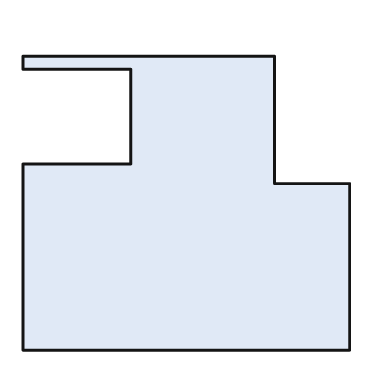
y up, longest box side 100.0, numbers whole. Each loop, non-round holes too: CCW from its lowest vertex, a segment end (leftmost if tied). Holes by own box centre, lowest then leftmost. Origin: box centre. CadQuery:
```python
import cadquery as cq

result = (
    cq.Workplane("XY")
    .moveTo(-50.0, -45.0)
    .lineTo(50.0, -45.0)
    .lineTo(50.0, 6.0)
    .lineTo(27.0, 6.0)
    .lineTo(27.0, 45.0)
    .lineTo(-50.0, 45.0)
    .lineTo(-50.0, 41.0)
    .lineTo(-17.0, 41.0)
    .lineTo(-17.0, 12.0)
    .lineTo(-50.0, 12.0)
    .close()
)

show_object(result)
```